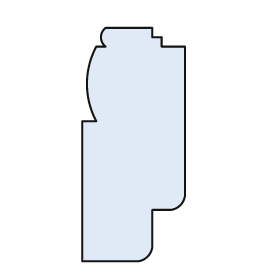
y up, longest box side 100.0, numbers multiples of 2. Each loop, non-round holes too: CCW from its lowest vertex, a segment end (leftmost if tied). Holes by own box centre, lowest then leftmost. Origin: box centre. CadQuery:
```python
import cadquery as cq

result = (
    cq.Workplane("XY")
    .moveTo(-22.0, -50.0)
    .lineTo(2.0, -50.0)
    .threePointArc((6.0, -48.0), (8.0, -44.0))
    .lineTo(8.0, -28.0)
    .lineTo(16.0, -28.0)
    .threePointArc((20.0, -26.0), (22.0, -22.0))
    .lineTo(22.0, 42.0)
    .lineTo(12.0, 42.0)
    .lineTo(12.0, 46.0)
    .lineTo(8.0, 46.0)
    .lineTo(8.0, 50.0)
    .lineTo(-12.0, 50.0)
    .threePointArc((-14.0, 46.0), (-12.0, 42.0))
    .lineTo(-16.0, 42.0)
    .threePointArc((-20.0, 26.0), (-16.0, 10.0))
    .lineTo(-22.0, 10.0)
    .close()
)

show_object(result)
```